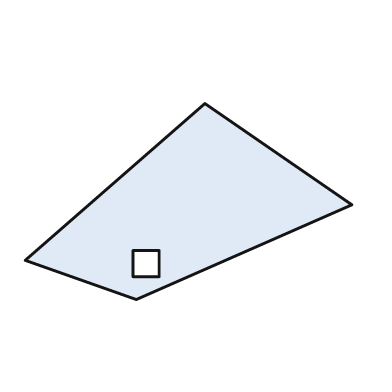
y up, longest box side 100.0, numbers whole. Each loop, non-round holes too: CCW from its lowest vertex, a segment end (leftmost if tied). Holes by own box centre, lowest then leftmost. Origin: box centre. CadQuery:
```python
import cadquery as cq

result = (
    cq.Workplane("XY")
    .moveTo(-16.0, -30.0)
    .lineTo(50.0, -1.0)
    .lineTo(5.0, 30.0)
    .lineTo(-50.0, -18.0)
    .close()
    .moveTo(-17.0, -23.0)
    .lineTo(-9.0, -23.0)
    .lineTo(-9.0, -15.0)
    .lineTo(-17.0, -15.0)
    .close()
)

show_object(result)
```